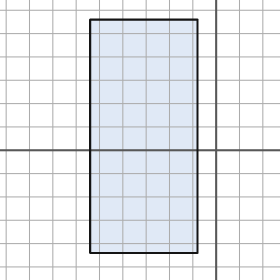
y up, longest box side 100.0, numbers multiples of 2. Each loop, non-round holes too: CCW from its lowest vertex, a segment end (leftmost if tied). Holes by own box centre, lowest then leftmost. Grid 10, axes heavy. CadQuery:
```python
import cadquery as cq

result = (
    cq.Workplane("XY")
    .moveTo(-54.0, -44.0)
    .lineTo(-8.0, -44.0)
    .lineTo(-8.0, 56.0)
    .lineTo(-54.0, 56.0)
    .close()
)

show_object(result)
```